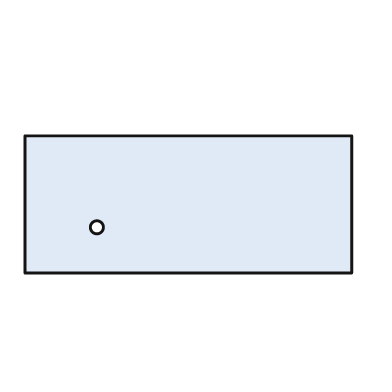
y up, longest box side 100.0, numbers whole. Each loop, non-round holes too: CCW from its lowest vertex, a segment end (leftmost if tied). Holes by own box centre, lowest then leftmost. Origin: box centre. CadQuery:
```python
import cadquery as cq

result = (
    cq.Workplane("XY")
    .moveTo(-50.0, -21.0)
    .lineTo(50.0, -21.0)
    .lineTo(50.0, 21.0)
    .lineTo(-50.0, 21.0)
    .close()
    .moveTo(-28.0, -7.0)
    .circle(2.0)
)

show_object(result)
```